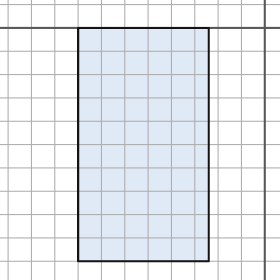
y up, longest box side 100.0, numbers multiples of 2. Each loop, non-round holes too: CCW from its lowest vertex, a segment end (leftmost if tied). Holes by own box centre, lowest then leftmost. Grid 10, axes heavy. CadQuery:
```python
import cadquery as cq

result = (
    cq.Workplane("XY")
    .moveTo(-80.0, -100.0)
    .lineTo(-24.0, -100.0)
    .lineTo(-24.0, 0.0)
    .lineTo(-80.0, 0.0)
    .close()
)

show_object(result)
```